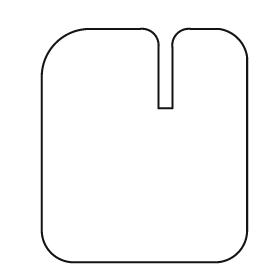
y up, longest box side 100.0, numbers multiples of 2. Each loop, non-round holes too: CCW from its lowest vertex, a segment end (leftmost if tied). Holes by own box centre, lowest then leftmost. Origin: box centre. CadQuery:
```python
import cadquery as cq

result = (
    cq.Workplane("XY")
    .moveTo(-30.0, -50.0)
    .lineTo(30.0, -50.0)
    .threePointArc((40.0, -46.0), (44.0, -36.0))
    .lineTo(44.0, 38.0)
    .threePointArc((40.0, 46.0), (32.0, 50.0))
    .lineTo(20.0, 50.0)
    .threePointArc((14.0, 48.0), (12.0, 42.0))
    .lineTo(12.0, 16.0)
    .lineTo(6.0, 16.0)
    .lineTo(6.0, 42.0)
    .threePointArc((4.0, 48.0), (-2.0, 50.0))
    .lineTo(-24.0, 50.0)
    .threePointArc((-38.0, 44.0), (-44.0, 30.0))
    .lineTo(-44.0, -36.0)
    .threePointArc((-40.0, -46.0), (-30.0, -50.0))
    .close()
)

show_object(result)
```